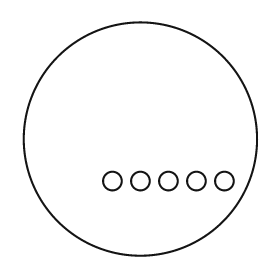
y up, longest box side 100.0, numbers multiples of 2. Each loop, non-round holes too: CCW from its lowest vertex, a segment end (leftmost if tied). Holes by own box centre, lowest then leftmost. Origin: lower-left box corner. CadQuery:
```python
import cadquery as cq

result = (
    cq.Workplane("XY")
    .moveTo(50.0, 50.0)
    .circle(50.0)
    .moveTo(38.0, 32.0)
    .circle(4.0)
    .moveTo(50.0, 32.0)
    .circle(4.0)
    .moveTo(62.0, 32.0)
    .circle(4.0)
    .moveTo(74.0, 32.0)
    .circle(4.0)
    .moveTo(86.0, 32.0)
    .circle(4.0)
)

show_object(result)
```